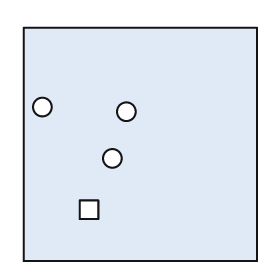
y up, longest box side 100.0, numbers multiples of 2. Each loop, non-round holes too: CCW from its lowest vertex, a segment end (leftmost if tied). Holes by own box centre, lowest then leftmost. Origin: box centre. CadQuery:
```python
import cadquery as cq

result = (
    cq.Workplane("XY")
    .moveTo(-50.0, -50.0)
    .lineTo(50.0, -50.0)
    .lineTo(50.0, 50.0)
    .lineTo(-50.0, 50.0)
    .close()
    .moveTo(-26.0, -32.0)
    .lineTo(-18.0, -32.0)
    .lineTo(-18.0, -24.0)
    .lineTo(-26.0, -24.0)
    .close()
    .moveTo(-12.0, -6.0)
    .circle(4.0)
    .moveTo(-6.0, 14.0)
    .circle(4.0)
    .moveTo(-42.0, 16.0)
    .circle(4.0)
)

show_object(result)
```